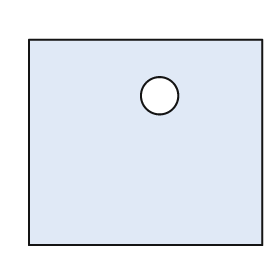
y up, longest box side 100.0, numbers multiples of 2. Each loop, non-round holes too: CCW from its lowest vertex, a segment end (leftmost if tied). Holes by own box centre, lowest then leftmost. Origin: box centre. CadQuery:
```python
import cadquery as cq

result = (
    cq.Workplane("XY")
    .moveTo(-50.0, -44.0)
    .lineTo(50.0, -44.0)
    .lineTo(50.0, 44.0)
    .lineTo(-50.0, 44.0)
    .close()
    .moveTo(6.0, 20.0)
    .circle(8.0)
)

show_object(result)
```